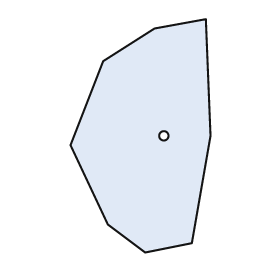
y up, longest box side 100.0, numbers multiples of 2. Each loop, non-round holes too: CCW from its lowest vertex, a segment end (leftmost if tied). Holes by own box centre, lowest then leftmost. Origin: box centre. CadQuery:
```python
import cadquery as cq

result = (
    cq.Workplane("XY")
    .moveTo(2.0, -50.0)
    .lineTo(22.0, -46.0)
    .lineTo(30.0, 0.0)
    .lineTo(28.0, 50.0)
    .lineTo(6.0, 46.0)
    .lineTo(-16.0, 32.0)
    .lineTo(-30.0, -4.0)
    .lineTo(-14.0, -38.0)
    .close()
    .moveTo(10.0, 0.0)
    .circle(2.0)
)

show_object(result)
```